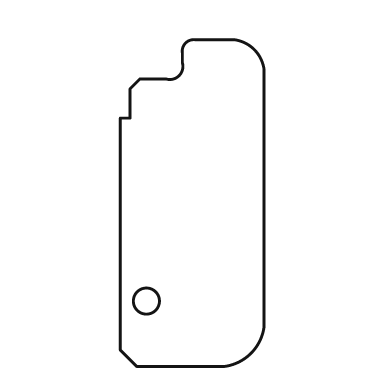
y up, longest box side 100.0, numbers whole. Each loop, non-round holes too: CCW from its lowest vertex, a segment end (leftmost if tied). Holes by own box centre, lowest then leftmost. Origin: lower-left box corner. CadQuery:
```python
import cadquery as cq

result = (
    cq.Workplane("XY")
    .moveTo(5.0, 0.0)
    .lineTo(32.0, 0.0)
    .threePointArc((40.0, 4.0), (44.0, 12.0))
    .lineTo(44.0, 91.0)
    .threePointArc((41.0, 97.0), (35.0, 100.0))
    .lineTo(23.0, 100.0)
    .threePointArc((20.0, 99.0), (19.0, 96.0))
    .lineTo(19.0, 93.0)
    .threePointArc((18.0, 89.0), (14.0, 88.0))
    .lineTo(6.0, 88.0)
    .lineTo(3.0, 85.0)
    .lineTo(3.0, 76.0)
    .lineTo(0.0, 76.0)
    .lineTo(0.0, 5.0)
    .close()
    .moveTo(8.0, 20.0)
    .circle(4.0)
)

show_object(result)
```